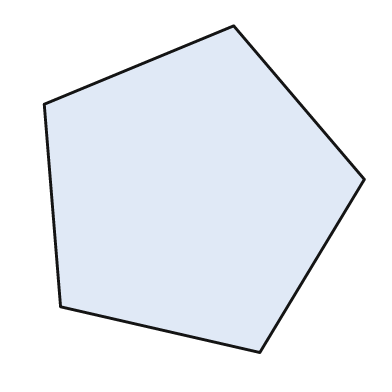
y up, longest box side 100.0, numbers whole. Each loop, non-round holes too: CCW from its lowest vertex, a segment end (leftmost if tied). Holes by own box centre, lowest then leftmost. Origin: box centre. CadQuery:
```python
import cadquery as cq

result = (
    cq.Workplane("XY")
    .moveTo(17.0, -50.0)
    .lineTo(49.0, 3.0)
    .lineTo(9.0, 50.0)
    .lineTo(-49.0, 26.0)
    .lineTo(-44.0, -36.0)
    .close()
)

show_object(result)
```